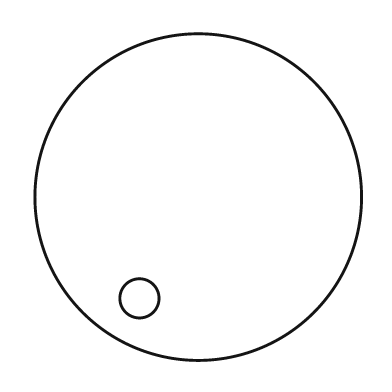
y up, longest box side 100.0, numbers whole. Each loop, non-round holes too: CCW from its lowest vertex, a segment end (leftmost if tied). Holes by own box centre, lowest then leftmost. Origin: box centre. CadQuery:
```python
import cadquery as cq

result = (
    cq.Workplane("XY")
    .moveTo(0.0, 0.0)
    .circle(50.0)
    .moveTo(-18.0, -31.0)
    .circle(6.0)
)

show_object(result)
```